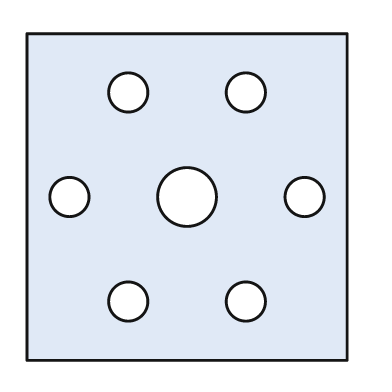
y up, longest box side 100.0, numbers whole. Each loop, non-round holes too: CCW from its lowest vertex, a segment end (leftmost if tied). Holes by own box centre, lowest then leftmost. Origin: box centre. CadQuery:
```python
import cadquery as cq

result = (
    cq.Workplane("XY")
    .moveTo(-49.0, -50.0)
    .lineTo(49.0, -50.0)
    .lineTo(49.0, 50.0)
    .lineTo(-49.0, 50.0)
    .close()
    .moveTo(-18.0, -32.0)
    .circle(6.0)
    .moveTo(18.0, -32.0)
    .circle(6.0)
    .moveTo(-36.0, 0.0)
    .circle(6.0)
    .moveTo(0.0, 0.0)
    .circle(9.0)
    .moveTo(36.0, 0.0)
    .circle(6.0)
    .moveTo(-18.0, 32.0)
    .circle(6.0)
    .moveTo(18.0, 32.0)
    .circle(6.0)
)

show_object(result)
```